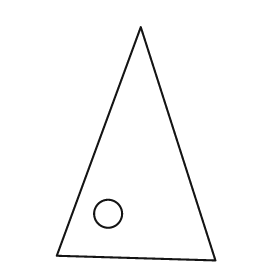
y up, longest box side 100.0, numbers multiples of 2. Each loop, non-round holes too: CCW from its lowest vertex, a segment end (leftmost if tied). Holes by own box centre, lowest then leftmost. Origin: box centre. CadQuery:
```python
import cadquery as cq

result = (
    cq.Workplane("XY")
    .moveTo(34.0, -50.0)
    .lineTo(2.0, 50.0)
    .lineTo(-34.0, -48.0)
    .close()
    .moveTo(-12.0, -30.0)
    .circle(6.0)
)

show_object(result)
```